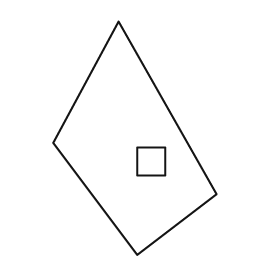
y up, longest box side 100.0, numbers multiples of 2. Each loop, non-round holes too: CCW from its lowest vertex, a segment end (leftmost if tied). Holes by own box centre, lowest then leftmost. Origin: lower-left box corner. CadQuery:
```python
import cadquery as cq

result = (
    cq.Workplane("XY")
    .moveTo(36.0, 0.0)
    .lineTo(70.0, 26.0)
    .lineTo(28.0, 100.0)
    .lineTo(0.0, 48.0)
    .close()
    .moveTo(36.0, 34.0)
    .lineTo(48.0, 34.0)
    .lineTo(48.0, 46.0)
    .lineTo(36.0, 46.0)
    .close()
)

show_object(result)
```